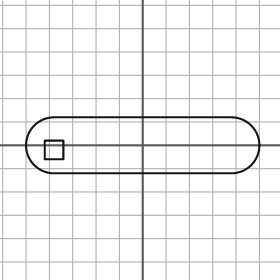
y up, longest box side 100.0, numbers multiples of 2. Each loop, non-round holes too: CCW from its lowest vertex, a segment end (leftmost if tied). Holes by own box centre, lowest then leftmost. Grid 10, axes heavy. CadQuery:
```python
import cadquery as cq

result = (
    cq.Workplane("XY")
    .moveTo(-38.0, -12.0)
    .lineTo(38.0, -12.0)
    .threePointArc((50.0, 0.0), (38.0, 12.0))
    .lineTo(-38.0, 12.0)
    .threePointArc((-50.0, 0.0), (-38.0, -12.0))
    .close()
    .moveTo(-42.0, -6.0)
    .lineTo(-34.0, -6.0)
    .lineTo(-34.0, 2.0)
    .lineTo(-42.0, 2.0)
    .close()
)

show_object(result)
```